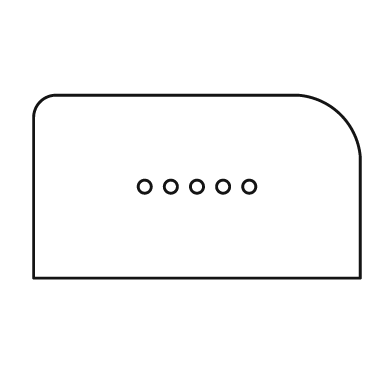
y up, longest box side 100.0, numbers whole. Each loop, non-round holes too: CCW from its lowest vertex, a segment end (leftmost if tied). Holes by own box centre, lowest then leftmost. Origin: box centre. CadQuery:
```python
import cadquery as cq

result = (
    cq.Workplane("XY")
    .moveTo(-50.0, -28.0)
    .lineTo(50.0, -28.0)
    .lineTo(50.0, 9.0)
    .threePointArc((44.0, 22.0), (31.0, 28.0))
    .lineTo(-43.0, 28.0)
    .threePointArc((-48.0, 26.0), (-50.0, 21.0))
    .close()
    .moveTo(-16.0, 0.0)
    .circle(2.0)
    .moveTo(-8.0, 0.0)
    .circle(2.0)
    .moveTo(0.0, 0.0)
    .circle(2.0)
    .moveTo(8.0, 0.0)
    .circle(2.0)
    .moveTo(16.0, 0.0)
    .circle(2.0)
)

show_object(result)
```